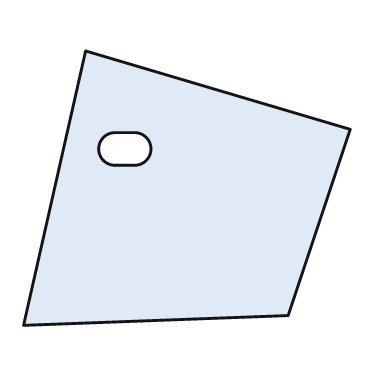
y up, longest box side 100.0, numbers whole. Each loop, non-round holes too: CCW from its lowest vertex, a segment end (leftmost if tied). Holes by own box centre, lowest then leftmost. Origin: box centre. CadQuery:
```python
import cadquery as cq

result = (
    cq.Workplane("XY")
    .moveTo(-50.0, -42.0)
    .lineTo(31.0, -39.0)
    .lineTo(50.0, 18.0)
    .lineTo(-31.0, 42.0)
    .close()
    .moveTo(-22.0, 7.0)
    .lineTo(-16.0, 7.0)
    .threePointArc((-11.0, 12.0), (-16.0, 17.0))
    .lineTo(-22.0, 17.0)
    .threePointArc((-27.0, 12.0), (-22.0, 7.0))
    .close()
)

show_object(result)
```